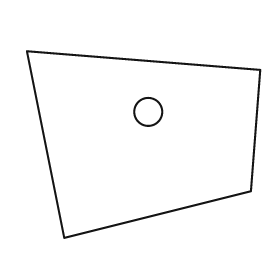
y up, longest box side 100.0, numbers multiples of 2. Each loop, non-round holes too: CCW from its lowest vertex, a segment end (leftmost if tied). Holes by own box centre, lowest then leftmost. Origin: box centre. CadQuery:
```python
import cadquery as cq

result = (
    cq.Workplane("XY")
    .moveTo(-34.0, -40.0)
    .lineTo(46.0, -20.0)
    .lineTo(50.0, 32.0)
    .lineTo(-50.0, 40.0)
    .close()
    .moveTo(2.0, 14.0)
    .circle(6.0)
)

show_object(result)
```